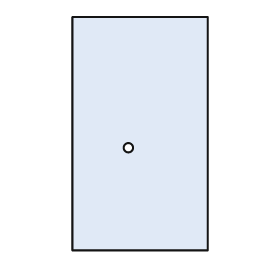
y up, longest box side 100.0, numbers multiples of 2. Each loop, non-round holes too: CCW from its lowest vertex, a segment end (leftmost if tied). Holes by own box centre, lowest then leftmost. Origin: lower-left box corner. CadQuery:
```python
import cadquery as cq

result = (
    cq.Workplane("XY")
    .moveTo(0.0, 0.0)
    .lineTo(58.0, 0.0)
    .lineTo(58.0, 100.0)
    .lineTo(0.0, 100.0)
    .close()
    .moveTo(24.0, 44.0)
    .circle(2.0)
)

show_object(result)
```